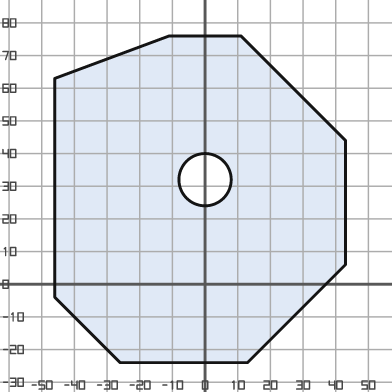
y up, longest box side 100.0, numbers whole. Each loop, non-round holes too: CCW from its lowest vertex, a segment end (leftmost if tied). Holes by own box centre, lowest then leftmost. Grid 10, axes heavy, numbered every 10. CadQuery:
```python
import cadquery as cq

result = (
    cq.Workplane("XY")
    .moveTo(-26.0, -24.0)
    .lineTo(13.0, -24.0)
    .lineTo(43.0, 6.0)
    .lineTo(43.0, 44.0)
    .lineTo(11.0, 76.0)
    .lineTo(-11.0, 76.0)
    .lineTo(-46.0, 63.0)
    .lineTo(-46.0, -4.0)
    .close()
    .moveTo(0.0, 32.0)
    .circle(8.0)
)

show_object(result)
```